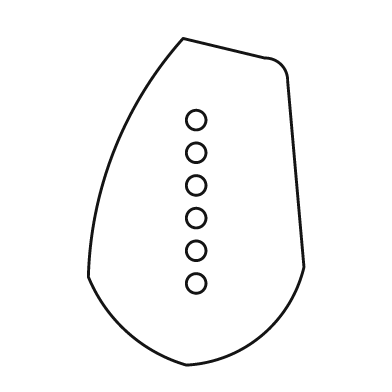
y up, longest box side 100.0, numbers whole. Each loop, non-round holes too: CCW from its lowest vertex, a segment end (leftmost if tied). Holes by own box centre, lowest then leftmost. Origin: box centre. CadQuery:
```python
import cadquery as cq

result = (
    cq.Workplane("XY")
    .moveTo(-3.0, -50.0)
    .threePointArc((20.0, -41.0), (33.0, -20.0))
    .lineTo(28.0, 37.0)
    .threePointArc((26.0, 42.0), (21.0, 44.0))
    .lineTo(-4.0, 50.0)
    .threePointArc((-25.0, 16.0), (-33.0, -23.0))
    .threePointArc((-21.0, -40.0), (-3.0, -50.0))
    .close()
    .moveTo(0.0, -25.0)
    .circle(3.0)
    .moveTo(0.0, -15.0)
    .circle(3.0)
    .moveTo(0.0, -5.0)
    .circle(3.0)
    .moveTo(0.0, 5.0)
    .circle(3.0)
    .moveTo(0.0, 15.0)
    .circle(3.0)
    .moveTo(0.0, 25.0)
    .circle(3.0)
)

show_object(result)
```